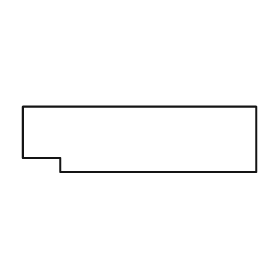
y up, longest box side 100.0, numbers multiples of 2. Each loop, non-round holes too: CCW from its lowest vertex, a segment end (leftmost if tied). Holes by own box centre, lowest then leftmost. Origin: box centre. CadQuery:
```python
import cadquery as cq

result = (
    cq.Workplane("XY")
    .moveTo(-34.0, -14.0)
    .lineTo(50.0, -14.0)
    .lineTo(50.0, 14.0)
    .lineTo(-50.0, 14.0)
    .lineTo(-50.0, -8.0)
    .lineTo(-34.0, -8.0)
    .close()
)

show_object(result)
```